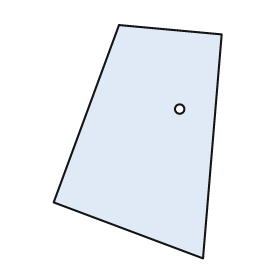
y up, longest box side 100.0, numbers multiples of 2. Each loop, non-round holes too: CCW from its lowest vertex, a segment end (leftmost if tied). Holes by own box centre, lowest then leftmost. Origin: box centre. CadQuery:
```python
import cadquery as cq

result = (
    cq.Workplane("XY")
    .moveTo(28.0, -50.0)
    .lineTo(36.0, 46.0)
    .lineTo(-8.0, 50.0)
    .lineTo(-36.0, -26.0)
    .close()
    .moveTo(18.0, 14.0)
    .circle(2.0)
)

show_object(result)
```